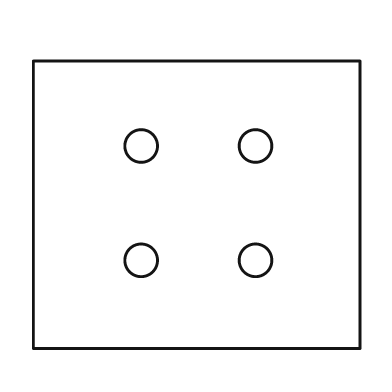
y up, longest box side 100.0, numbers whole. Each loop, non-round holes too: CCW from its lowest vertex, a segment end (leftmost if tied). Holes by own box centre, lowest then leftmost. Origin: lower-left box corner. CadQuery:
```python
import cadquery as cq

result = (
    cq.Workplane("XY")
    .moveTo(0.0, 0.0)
    .lineTo(100.0, 0.0)
    .lineTo(100.0, 88.0)
    .lineTo(0.0, 88.0)
    .close()
    .moveTo(33.0, 27.0)
    .circle(5.0)
    .moveTo(68.0, 27.0)
    .circle(5.0)
    .moveTo(33.0, 62.0)
    .circle(5.0)
    .moveTo(68.0, 62.0)
    .circle(5.0)
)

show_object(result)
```